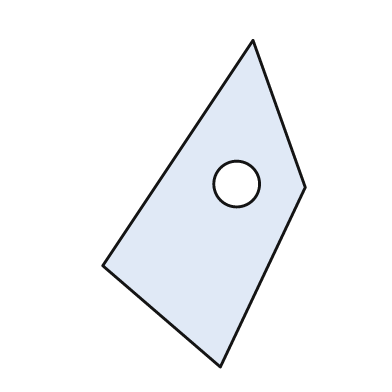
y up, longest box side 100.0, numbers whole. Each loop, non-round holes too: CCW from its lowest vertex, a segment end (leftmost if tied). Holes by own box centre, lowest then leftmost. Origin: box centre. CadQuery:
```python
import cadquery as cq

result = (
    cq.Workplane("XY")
    .moveTo(5.0, -50.0)
    .lineTo(31.0, 5.0)
    .lineTo(15.0, 50.0)
    .lineTo(-31.0, -19.0)
    .close()
    .moveTo(10.0, 6.0)
    .circle(7.0)
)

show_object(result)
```